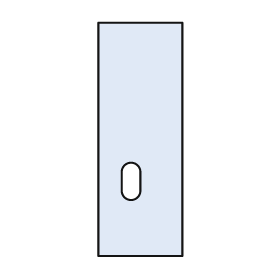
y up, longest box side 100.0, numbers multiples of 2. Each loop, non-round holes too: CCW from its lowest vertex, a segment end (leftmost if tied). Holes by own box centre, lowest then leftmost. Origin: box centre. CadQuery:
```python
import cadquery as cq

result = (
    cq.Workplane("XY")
    .moveTo(-18.0, -50.0)
    .lineTo(18.0, -50.0)
    .lineTo(18.0, 50.0)
    .lineTo(-18.0, 50.0)
    .close()
    .moveTo(-8.0, -22.0)
    .threePointArc((-4.0, -26.0), (0.0, -22.0))
    .lineTo(0.0, -14.0)
    .threePointArc((-4.0, -10.0), (-8.0, -14.0))
    .close()
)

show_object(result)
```